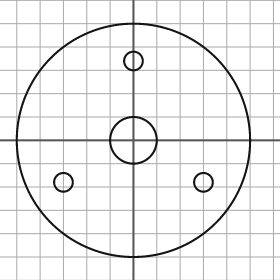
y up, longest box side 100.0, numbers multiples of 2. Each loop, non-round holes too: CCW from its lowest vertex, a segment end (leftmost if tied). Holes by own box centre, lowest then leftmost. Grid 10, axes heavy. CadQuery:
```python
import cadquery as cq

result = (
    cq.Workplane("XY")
    .moveTo(0.0, 0.0)
    .circle(50.0)
    .moveTo(-30.0, -18.0)
    .circle(4.0)
    .moveTo(30.0, -18.0)
    .circle(4.0)
    .moveTo(0.0, 0.0)
    .circle(10.0)
    .moveTo(0.0, 34.0)
    .circle(4.0)
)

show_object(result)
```